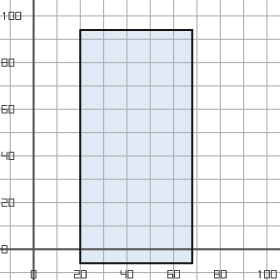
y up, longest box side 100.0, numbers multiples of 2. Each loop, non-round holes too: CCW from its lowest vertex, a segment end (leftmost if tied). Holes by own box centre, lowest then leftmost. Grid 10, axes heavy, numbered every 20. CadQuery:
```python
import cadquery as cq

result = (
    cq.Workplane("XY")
    .moveTo(20.0, -6.0)
    .lineTo(68.0, -6.0)
    .lineTo(68.0, 94.0)
    .lineTo(20.0, 94.0)
    .close()
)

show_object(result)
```